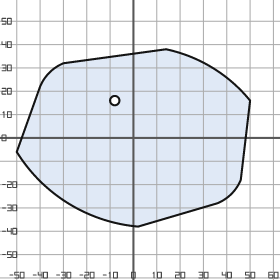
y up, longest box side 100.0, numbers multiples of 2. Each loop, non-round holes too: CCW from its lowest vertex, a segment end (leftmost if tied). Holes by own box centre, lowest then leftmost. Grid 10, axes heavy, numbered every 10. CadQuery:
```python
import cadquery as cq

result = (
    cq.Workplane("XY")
    .moveTo(2.0, -38.0)
    .lineTo(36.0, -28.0)
    .threePointArc((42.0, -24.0), (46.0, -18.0))
    .lineTo(50.0, 16.0)
    .threePointArc((34.0, 30.0), (14.0, 38.0))
    .lineTo(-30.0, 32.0)
    .threePointArc((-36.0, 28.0), (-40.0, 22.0))
    .lineTo(-50.0, -6.0)
    .threePointArc((-28.0, -28.0), (2.0, -38.0))
    .close()
    .moveTo(-8.0, 16.0)
    .circle(2.0)
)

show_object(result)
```